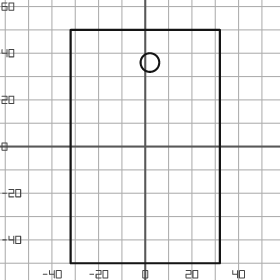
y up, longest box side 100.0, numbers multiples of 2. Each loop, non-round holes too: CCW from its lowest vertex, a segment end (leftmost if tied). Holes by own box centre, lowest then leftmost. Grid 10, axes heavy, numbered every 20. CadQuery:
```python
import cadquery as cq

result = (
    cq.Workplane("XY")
    .moveTo(-32.0, -50.0)
    .lineTo(32.0, -50.0)
    .lineTo(32.0, 50.0)
    .lineTo(-32.0, 50.0)
    .close()
    .moveTo(2.0, 36.0)
    .circle(4.0)
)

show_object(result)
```